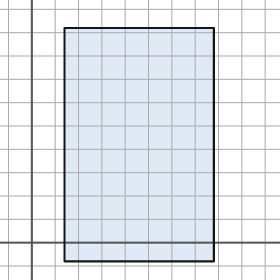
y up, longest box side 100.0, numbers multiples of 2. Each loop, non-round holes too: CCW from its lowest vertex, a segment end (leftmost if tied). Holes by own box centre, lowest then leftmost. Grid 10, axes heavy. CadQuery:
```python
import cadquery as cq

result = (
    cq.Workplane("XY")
    .moveTo(14.0, -8.0)
    .lineTo(78.0, -8.0)
    .lineTo(78.0, 92.0)
    .lineTo(14.0, 92.0)
    .close()
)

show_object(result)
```